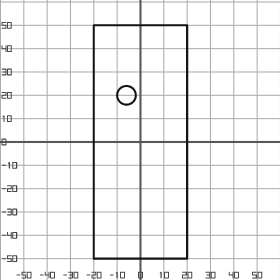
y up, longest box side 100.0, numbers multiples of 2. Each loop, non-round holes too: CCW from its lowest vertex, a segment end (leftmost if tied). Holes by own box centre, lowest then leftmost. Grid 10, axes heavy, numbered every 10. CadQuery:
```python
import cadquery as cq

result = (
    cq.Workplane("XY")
    .moveTo(-20.0, -50.0)
    .lineTo(20.0, -50.0)
    .lineTo(20.0, 50.0)
    .lineTo(-20.0, 50.0)
    .close()
    .moveTo(-6.0, 20.0)
    .circle(4.0)
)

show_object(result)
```